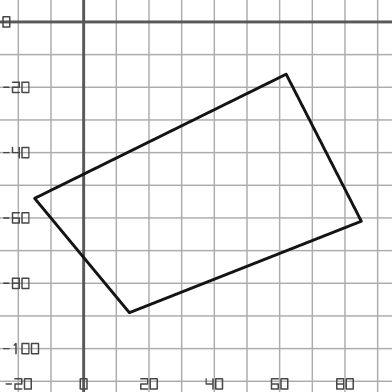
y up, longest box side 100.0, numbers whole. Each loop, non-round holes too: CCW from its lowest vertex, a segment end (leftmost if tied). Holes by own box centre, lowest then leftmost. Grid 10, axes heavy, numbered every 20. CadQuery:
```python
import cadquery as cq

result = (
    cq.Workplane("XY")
    .moveTo(14.0, -89.0)
    .lineTo(85.0, -61.0)
    .lineTo(62.0, -16.0)
    .lineTo(-15.0, -54.0)
    .close()
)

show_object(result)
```